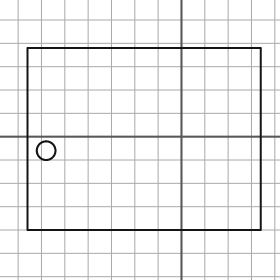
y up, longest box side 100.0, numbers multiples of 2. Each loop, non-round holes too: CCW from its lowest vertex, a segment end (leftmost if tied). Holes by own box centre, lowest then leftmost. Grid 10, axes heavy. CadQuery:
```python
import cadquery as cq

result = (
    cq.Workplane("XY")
    .moveTo(-66.0, -40.0)
    .lineTo(34.0, -40.0)
    .lineTo(34.0, 38.0)
    .lineTo(-66.0, 38.0)
    .close()
    .moveTo(-58.0, -6.0)
    .circle(4.0)
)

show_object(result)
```